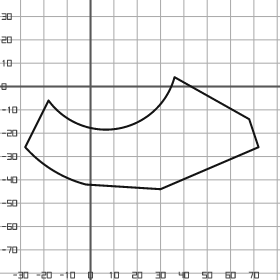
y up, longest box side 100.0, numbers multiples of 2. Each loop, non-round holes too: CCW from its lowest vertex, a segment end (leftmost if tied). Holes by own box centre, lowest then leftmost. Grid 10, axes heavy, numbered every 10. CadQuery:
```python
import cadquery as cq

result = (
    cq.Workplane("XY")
    .moveTo(30.0, -44.0)
    .lineTo(72.0, -26.0)
    .lineTo(68.0, -14.0)
    .lineTo(36.0, 4.0)
    .threePointArc((12.0, -18.0), (-18.0, -6.0))
    .lineTo(-28.0, -26.0)
    .threePointArc((-16.0, -36.0), (-2.0, -42.0))
    .close()
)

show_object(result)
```